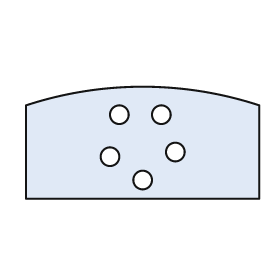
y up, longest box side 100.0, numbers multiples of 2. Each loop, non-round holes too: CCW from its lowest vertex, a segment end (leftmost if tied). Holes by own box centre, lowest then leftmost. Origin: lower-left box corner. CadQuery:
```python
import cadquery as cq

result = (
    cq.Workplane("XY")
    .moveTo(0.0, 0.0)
    .lineTo(100.0, 0.0)
    .lineTo(100.0, 40.0)
    .threePointArc((50.0, 48.0), (0.0, 40.0))
    .close()
    .moveTo(50.0, 8.0)
    .circle(4.0)
    .moveTo(36.0, 18.0)
    .circle(4.0)
    .moveTo(64.0, 20.0)
    .circle(4.0)
    .moveTo(40.0, 36.0)
    .circle(4.0)
    .moveTo(58.0, 36.0)
    .circle(4.0)
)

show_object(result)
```